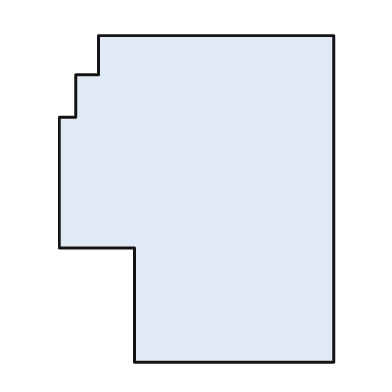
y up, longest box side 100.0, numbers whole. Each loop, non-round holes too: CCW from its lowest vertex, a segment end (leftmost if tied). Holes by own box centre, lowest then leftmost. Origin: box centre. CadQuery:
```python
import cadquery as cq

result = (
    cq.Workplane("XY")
    .moveTo(-19.0, -50.0)
    .lineTo(42.0, -50.0)
    .lineTo(42.0, 50.0)
    .lineTo(-30.0, 50.0)
    .lineTo(-30.0, 38.0)
    .lineTo(-37.0, 38.0)
    .lineTo(-37.0, 25.0)
    .lineTo(-42.0, 25.0)
    .lineTo(-42.0, -15.0)
    .lineTo(-19.0, -15.0)
    .close()
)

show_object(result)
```